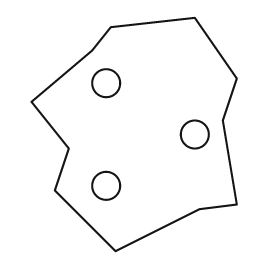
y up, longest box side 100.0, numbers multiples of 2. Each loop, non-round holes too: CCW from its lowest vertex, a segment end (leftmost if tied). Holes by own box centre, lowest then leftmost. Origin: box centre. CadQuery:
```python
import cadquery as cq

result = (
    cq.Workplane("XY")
    .moveTo(-8.0, -50.0)
    .lineTo(28.0, -32.0)
    .lineTo(44.0, -30.0)
    .lineTo(38.0, 6.0)
    .lineTo(44.0, 24.0)
    .lineTo(26.0, 50.0)
    .lineTo(-10.0, 46.0)
    .lineTo(-18.0, 36.0)
    .lineTo(-44.0, 14.0)
    .lineTo(-28.0, -6.0)
    .lineTo(-34.0, -24.0)
    .close()
    .moveTo(-12.0, -22.0)
    .circle(6.0)
    .moveTo(26.0, 0.0)
    .circle(6.0)
    .moveTo(-12.0, 22.0)
    .circle(6.0)
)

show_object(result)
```